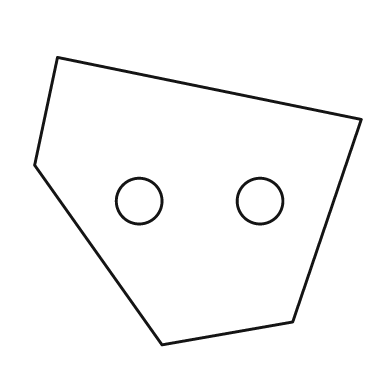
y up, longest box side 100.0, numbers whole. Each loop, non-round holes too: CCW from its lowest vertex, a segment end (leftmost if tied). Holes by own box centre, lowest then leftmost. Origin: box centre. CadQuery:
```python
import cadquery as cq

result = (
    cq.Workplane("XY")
    .moveTo(-11.0, -44.0)
    .lineTo(29.0, -37.0)
    .lineTo(50.0, 25.0)
    .lineTo(-43.0, 44.0)
    .lineTo(-50.0, 11.0)
    .close()
    .moveTo(-18.0, 0.0)
    .circle(7.0)
    .moveTo(19.0, 0.0)
    .circle(7.0)
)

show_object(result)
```